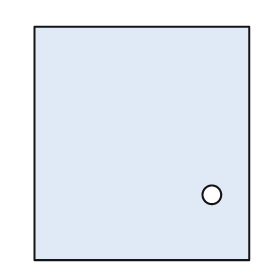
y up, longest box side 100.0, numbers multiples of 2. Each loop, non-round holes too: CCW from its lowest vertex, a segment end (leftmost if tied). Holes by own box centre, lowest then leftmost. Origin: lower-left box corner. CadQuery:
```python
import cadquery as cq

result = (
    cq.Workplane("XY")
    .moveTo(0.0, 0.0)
    .lineTo(92.0, 0.0)
    .lineTo(92.0, 100.0)
    .lineTo(0.0, 100.0)
    .close()
    .moveTo(76.0, 28.0)
    .circle(4.0)
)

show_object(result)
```